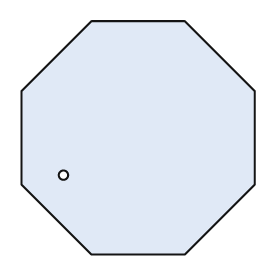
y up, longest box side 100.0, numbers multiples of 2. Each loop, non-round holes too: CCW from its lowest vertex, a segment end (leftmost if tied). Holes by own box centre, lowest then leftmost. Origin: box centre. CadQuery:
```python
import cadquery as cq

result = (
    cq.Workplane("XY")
    .moveTo(-20.0, -50.0)
    .lineTo(20.0, -50.0)
    .lineTo(50.0, -20.0)
    .lineTo(50.0, 20.0)
    .lineTo(20.0, 50.0)
    .lineTo(-20.0, 50.0)
    .lineTo(-50.0, 20.0)
    .lineTo(-50.0, -20.0)
    .close()
    .moveTo(-32.0, -16.0)
    .circle(2.0)
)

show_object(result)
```